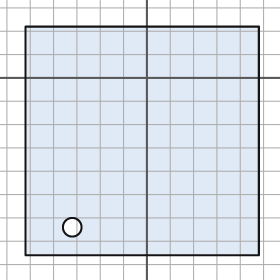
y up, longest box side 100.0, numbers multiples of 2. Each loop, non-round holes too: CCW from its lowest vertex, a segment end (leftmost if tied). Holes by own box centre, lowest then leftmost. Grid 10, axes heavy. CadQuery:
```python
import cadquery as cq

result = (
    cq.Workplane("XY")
    .moveTo(-52.0, -76.0)
    .lineTo(48.0, -76.0)
    .lineTo(48.0, 22.0)
    .lineTo(-52.0, 22.0)
    .close()
    .moveTo(-32.0, -64.0)
    .circle(4.0)
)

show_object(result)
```